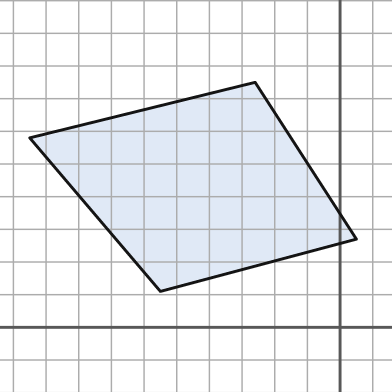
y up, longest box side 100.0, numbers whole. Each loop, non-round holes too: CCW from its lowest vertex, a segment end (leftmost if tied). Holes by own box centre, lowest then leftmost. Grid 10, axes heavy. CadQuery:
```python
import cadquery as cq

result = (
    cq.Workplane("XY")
    .moveTo(-55.0, 11.0)
    .lineTo(5.0, 27.0)
    .lineTo(-26.0, 75.0)
    .lineTo(-95.0, 58.0)
    .close()
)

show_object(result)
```